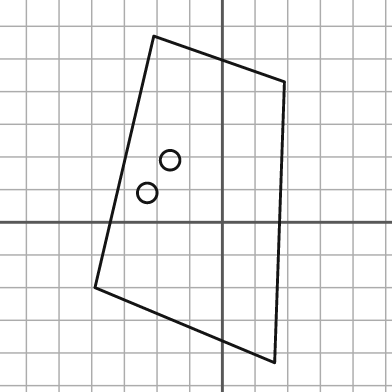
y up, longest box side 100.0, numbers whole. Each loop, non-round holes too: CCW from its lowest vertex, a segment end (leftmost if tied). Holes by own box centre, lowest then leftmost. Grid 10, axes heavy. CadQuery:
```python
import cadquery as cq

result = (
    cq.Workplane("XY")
    .moveTo(16.0, -43.0)
    .lineTo(19.0, 43.0)
    .lineTo(-21.0, 57.0)
    .lineTo(-39.0, -20.0)
    .close()
    .moveTo(-23.0, 9.0)
    .circle(3.0)
    .moveTo(-16.0, 19.0)
    .circle(3.0)
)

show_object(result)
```